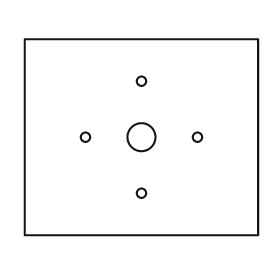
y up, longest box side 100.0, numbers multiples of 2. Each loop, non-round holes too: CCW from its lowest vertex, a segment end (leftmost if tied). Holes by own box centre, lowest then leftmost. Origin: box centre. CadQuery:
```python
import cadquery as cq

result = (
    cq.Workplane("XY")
    .moveTo(-50.0, -42.0)
    .lineTo(50.0, -42.0)
    .lineTo(50.0, 42.0)
    .lineTo(-50.0, 42.0)
    .close()
    .moveTo(0.0, -24.0)
    .circle(2.0)
    .moveTo(-24.0, 0.0)
    .circle(2.0)
    .moveTo(0.0, 0.0)
    .circle(6.0)
    .moveTo(24.0, 0.0)
    .circle(2.0)
    .moveTo(0.0, 24.0)
    .circle(2.0)
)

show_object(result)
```